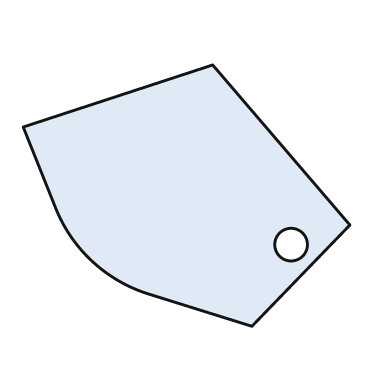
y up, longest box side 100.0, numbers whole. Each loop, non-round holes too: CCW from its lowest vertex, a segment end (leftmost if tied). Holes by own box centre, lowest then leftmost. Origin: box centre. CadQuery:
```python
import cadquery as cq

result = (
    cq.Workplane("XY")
    .moveTo(20.0, -40.0)
    .lineTo(50.0, -9.0)
    .lineTo(8.0, 40.0)
    .lineTo(-50.0, 21.0)
    .lineTo(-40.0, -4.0)
    .threePointArc((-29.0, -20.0), (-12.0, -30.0))
    .close()
    .moveTo(32.0, -15.0)
    .circle(5.0)
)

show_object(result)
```